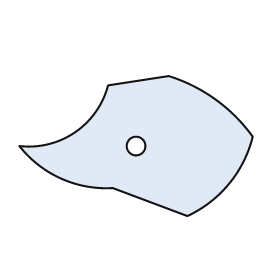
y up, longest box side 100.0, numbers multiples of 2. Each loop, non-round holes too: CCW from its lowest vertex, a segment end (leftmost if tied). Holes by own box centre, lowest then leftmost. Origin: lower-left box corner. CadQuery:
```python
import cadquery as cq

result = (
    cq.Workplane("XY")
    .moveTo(72.0, 0.0)
    .threePointArc((90.0, 14.0), (100.0, 34.0))
    .threePointArc((84.0, 50.0), (64.0, 60.0))
    .lineTo(38.0, 56.0)
    .threePointArc((24.0, 36.0), (0.0, 30.0))
    .threePointArc((18.0, 16.0), (40.0, 12.0))
    .close()
    .moveTo(50.0, 30.0)
    .circle(4.0)
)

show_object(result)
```